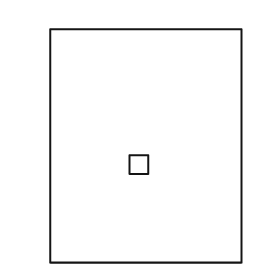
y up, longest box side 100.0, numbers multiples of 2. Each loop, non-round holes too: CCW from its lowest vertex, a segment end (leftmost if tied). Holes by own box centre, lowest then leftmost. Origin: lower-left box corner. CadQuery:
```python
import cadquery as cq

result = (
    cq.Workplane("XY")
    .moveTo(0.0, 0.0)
    .lineTo(82.0, 0.0)
    .lineTo(82.0, 100.0)
    .lineTo(0.0, 100.0)
    .close()
    .moveTo(34.0, 38.0)
    .lineTo(42.0, 38.0)
    .lineTo(42.0, 46.0)
    .lineTo(34.0, 46.0)
    .close()
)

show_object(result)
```